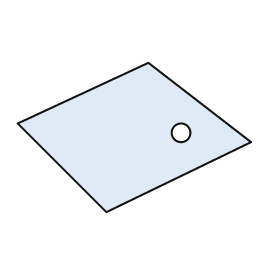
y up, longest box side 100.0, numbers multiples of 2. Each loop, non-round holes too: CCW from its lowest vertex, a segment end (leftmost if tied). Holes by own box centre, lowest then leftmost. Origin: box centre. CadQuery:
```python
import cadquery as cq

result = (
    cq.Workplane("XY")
    .moveTo(-12.0, -32.0)
    .lineTo(50.0, -2.0)
    .lineTo(6.0, 32.0)
    .lineTo(-50.0, 6.0)
    .close()
    .moveTo(20.0, 2.0)
    .circle(4.0)
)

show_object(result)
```